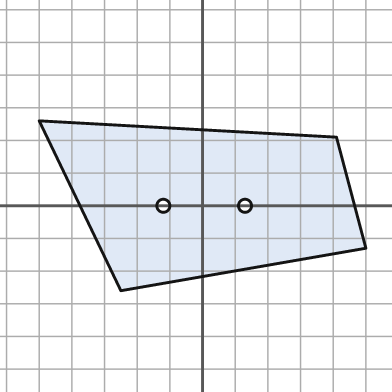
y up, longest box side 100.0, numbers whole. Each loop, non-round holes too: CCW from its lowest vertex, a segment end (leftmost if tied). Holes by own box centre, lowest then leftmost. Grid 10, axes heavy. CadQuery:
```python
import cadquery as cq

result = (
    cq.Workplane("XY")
    .moveTo(-25.0, -26.0)
    .lineTo(50.0, -13.0)
    .lineTo(41.0, 21.0)
    .lineTo(-50.0, 26.0)
    .close()
    .moveTo(-12.0, 0.0)
    .circle(2.0)
    .moveTo(13.0, 0.0)
    .circle(2.0)
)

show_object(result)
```